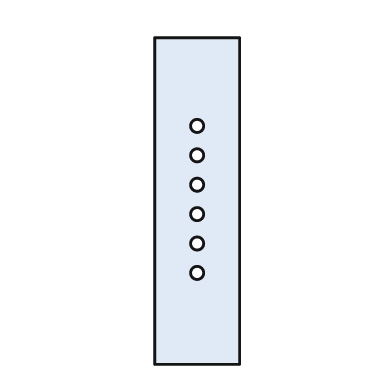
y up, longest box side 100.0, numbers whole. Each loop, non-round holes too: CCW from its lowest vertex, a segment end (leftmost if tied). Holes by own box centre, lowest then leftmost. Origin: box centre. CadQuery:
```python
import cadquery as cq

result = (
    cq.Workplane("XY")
    .moveTo(-13.0, -50.0)
    .lineTo(13.0, -50.0)
    .lineTo(13.0, 50.0)
    .lineTo(-13.0, 50.0)
    .close()
    .moveTo(0.0, -22.0)
    .circle(2.0)
    .moveTo(0.0, -13.0)
    .circle(2.0)
    .moveTo(0.0, -4.0)
    .circle(2.0)
    .moveTo(0.0, 5.0)
    .circle(2.0)
    .moveTo(0.0, 14.0)
    .circle(2.0)
    .moveTo(0.0, 23.0)
    .circle(2.0)
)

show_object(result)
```